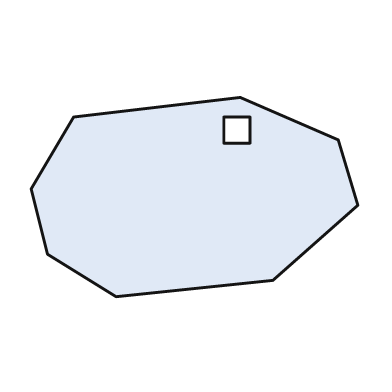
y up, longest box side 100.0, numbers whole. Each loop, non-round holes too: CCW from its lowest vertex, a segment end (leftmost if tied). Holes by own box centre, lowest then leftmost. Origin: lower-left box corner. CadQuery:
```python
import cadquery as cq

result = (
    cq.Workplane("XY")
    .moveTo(26.0, 0.0)
    .lineTo(74.0, 5.0)
    .lineTo(100.0, 28.0)
    .lineTo(94.0, 48.0)
    .lineTo(64.0, 61.0)
    .lineTo(13.0, 55.0)
    .lineTo(0.0, 33.0)
    .lineTo(5.0, 13.0)
    .close()
    .moveTo(59.0, 47.0)
    .lineTo(67.0, 47.0)
    .lineTo(67.0, 55.0)
    .lineTo(59.0, 55.0)
    .close()
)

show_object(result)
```